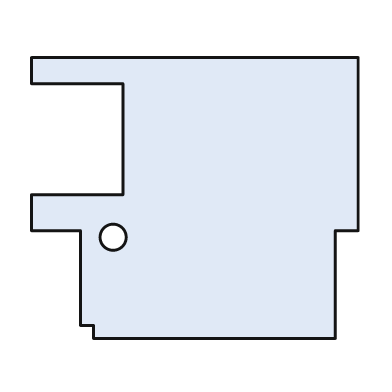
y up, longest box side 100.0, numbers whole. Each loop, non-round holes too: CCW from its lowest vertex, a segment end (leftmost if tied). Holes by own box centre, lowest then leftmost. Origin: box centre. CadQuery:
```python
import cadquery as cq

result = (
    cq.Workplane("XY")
    .moveTo(-31.0, -43.0)
    .lineTo(43.0, -43.0)
    .lineTo(43.0, -10.0)
    .lineTo(50.0, -10.0)
    .lineTo(50.0, 43.0)
    .lineTo(-50.0, 43.0)
    .lineTo(-50.0, 35.0)
    .lineTo(-22.0, 35.0)
    .lineTo(-22.0, 1.0)
    .lineTo(-50.0, 1.0)
    .lineTo(-50.0, -10.0)
    .lineTo(-35.0, -10.0)
    .lineTo(-35.0, -39.0)
    .lineTo(-31.0, -39.0)
    .close()
    .moveTo(-25.0, -12.0)
    .circle(4.0)
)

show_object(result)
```